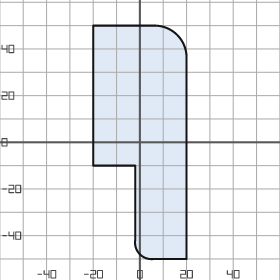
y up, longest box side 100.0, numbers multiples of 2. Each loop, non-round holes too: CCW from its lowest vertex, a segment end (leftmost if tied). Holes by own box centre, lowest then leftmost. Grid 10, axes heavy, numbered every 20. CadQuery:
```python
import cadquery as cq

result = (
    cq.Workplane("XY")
    .moveTo(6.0, -50.0)
    .lineTo(20.0, -50.0)
    .lineTo(20.0, 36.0)
    .threePointArc((16.0, 46.0), (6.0, 50.0))
    .lineTo(-20.0, 50.0)
    .lineTo(-20.0, -10.0)
    .lineTo(-2.0, -10.0)
    .lineTo(-2.0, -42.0)
    .threePointArc((0.0, -48.0), (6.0, -50.0))
    .close()
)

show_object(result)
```